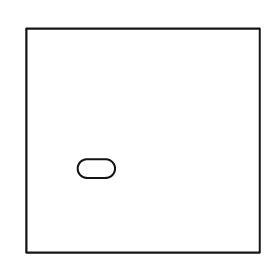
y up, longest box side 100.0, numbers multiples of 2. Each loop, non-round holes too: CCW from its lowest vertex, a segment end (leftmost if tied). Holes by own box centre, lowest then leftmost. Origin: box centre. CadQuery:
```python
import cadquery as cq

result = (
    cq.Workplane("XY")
    .moveTo(-50.0, -48.0)
    .lineTo(50.0, -48.0)
    .lineTo(50.0, 48.0)
    .lineTo(-50.0, 48.0)
    .close()
    .moveTo(-24.0, -16.0)
    .lineTo(-16.0, -16.0)
    .threePointArc((-12.0, -12.0), (-16.0, -8.0))
    .lineTo(-24.0, -8.0)
    .threePointArc((-28.0, -12.0), (-24.0, -16.0))
    .close()
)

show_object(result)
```